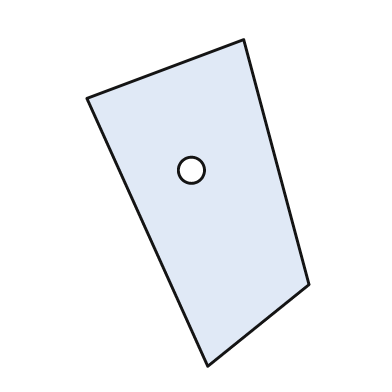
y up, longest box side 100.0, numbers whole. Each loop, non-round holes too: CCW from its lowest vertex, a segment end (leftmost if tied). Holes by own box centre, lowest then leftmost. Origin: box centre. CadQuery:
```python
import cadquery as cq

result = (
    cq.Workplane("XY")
    .moveTo(3.0, -50.0)
    .lineTo(34.0, -25.0)
    .lineTo(14.0, 50.0)
    .lineTo(-34.0, 32.0)
    .close()
    .moveTo(-2.0, 10.0)
    .circle(4.0)
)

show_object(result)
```